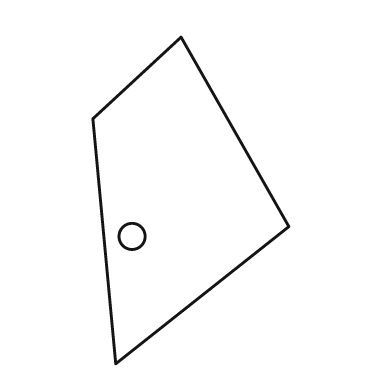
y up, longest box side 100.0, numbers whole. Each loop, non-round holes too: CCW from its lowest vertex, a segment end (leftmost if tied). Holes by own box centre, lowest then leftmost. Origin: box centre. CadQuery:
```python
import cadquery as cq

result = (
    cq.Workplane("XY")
    .moveTo(-23.0, -50.0)
    .lineTo(30.0, -8.0)
    .lineTo(-3.0, 50.0)
    .lineTo(-30.0, 25.0)
    .close()
    .moveTo(-18.0, -11.0)
    .circle(4.0)
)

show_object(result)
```